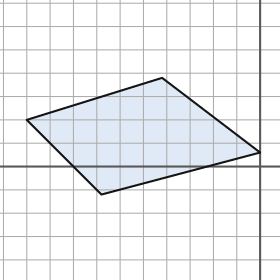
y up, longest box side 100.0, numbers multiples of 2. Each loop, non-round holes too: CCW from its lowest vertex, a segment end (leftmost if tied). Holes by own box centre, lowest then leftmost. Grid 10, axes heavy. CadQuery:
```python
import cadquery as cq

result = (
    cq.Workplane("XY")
    .moveTo(-68.0, -12.0)
    .lineTo(0.0, 6.0)
    .lineTo(-42.0, 38.0)
    .lineTo(-100.0, 20.0)
    .close()
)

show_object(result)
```